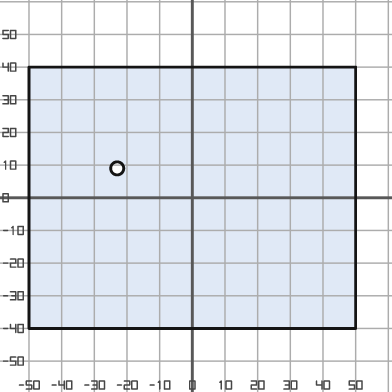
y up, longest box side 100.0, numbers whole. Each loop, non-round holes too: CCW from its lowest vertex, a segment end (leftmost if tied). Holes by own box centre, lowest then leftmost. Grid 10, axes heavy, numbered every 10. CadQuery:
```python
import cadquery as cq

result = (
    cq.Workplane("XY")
    .moveTo(-50.0, -40.0)
    .lineTo(50.0, -40.0)
    .lineTo(50.0, 40.0)
    .lineTo(-50.0, 40.0)
    .close()
    .moveTo(-23.0, 9.0)
    .circle(2.0)
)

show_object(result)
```